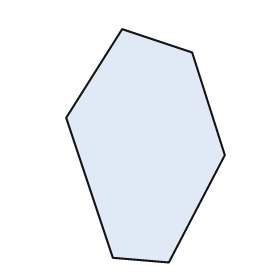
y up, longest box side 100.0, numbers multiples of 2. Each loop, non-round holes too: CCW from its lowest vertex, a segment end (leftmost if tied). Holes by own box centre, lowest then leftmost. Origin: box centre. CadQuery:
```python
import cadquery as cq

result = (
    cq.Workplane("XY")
    .moveTo(10.0, -50.0)
    .lineTo(34.0, -4.0)
    .lineTo(20.0, 40.0)
    .lineTo(-10.0, 50.0)
    .lineTo(-34.0, 12.0)
    .lineTo(-14.0, -48.0)
    .close()
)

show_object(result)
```